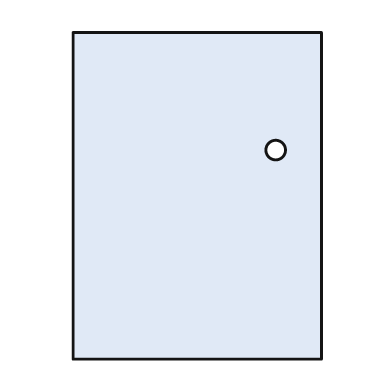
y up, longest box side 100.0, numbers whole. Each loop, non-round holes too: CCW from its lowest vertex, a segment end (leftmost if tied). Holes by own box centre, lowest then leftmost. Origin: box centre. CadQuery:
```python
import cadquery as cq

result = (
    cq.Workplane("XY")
    .moveTo(-38.0, -50.0)
    .lineTo(38.0, -50.0)
    .lineTo(38.0, 50.0)
    .lineTo(-38.0, 50.0)
    .close()
    .moveTo(24.0, 14.0)
    .circle(3.0)
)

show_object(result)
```